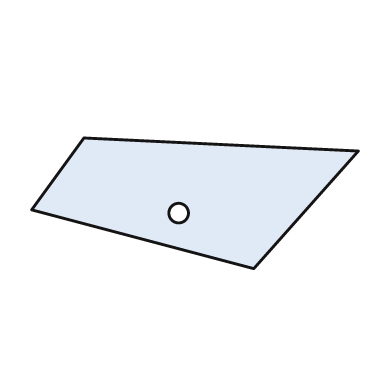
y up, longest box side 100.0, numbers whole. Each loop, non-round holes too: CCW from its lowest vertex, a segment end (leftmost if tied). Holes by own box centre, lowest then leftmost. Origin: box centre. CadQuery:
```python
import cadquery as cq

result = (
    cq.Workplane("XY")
    .moveTo(18.0, -20.0)
    .lineTo(50.0, 16.0)
    .lineTo(-34.0, 20.0)
    .lineTo(-50.0, -2.0)
    .close()
    .moveTo(-5.0, -3.0)
    .circle(3.0)
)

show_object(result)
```